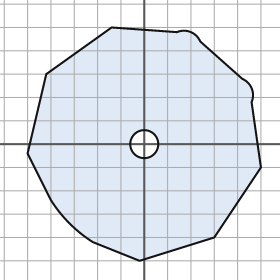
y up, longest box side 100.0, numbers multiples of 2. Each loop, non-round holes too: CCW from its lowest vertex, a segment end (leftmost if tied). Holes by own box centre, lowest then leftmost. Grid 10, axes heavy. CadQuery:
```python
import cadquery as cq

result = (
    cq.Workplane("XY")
    .moveTo(-2.0, -50.0)
    .lineTo(30.0, -40.0)
    .lineTo(50.0, -10.0)
    .lineTo(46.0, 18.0)
    .threePointArc((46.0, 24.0), (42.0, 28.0))
    .lineTo(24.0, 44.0)
    .threePointArc((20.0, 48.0), (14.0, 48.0))
    .lineTo(-14.0, 50.0)
    .lineTo(-42.0, 30.0)
    .lineTo(-50.0, -4.0)
    .lineTo(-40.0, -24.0)
    .threePointArc((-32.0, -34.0), (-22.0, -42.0))
    .close()
    .moveTo(0.0, 0.0)
    .circle(6.0)
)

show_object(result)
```